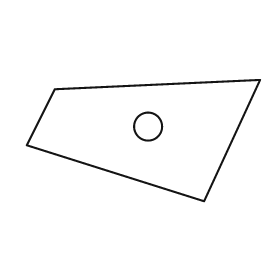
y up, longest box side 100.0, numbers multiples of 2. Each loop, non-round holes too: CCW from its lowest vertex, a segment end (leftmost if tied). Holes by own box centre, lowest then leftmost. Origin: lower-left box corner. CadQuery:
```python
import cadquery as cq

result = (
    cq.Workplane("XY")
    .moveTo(76.0, 0.0)
    .lineTo(100.0, 52.0)
    .lineTo(12.0, 48.0)
    .lineTo(0.0, 24.0)
    .close()
    .moveTo(52.0, 32.0)
    .circle(6.0)
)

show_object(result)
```